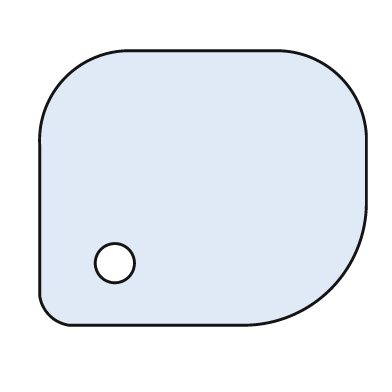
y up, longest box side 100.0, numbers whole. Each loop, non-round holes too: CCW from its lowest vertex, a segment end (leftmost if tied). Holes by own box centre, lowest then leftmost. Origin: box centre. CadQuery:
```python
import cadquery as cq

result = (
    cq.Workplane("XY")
    .moveTo(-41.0, -42.0)
    .lineTo(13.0, -42.0)
    .threePointArc((39.0, -31.0), (50.0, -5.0))
    .lineTo(50.0, 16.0)
    .threePointArc((42.0, 34.0), (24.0, 42.0))
    .lineTo(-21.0, 42.0)
    .threePointArc((-42.0, 34.0), (-50.0, 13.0))
    .lineTo(-50.0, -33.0)
    .threePointArc((-47.0, -39.0), (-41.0, -42.0))
    .close()
    .moveTo(-27.0, -23.0)
    .circle(6.0)
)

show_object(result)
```